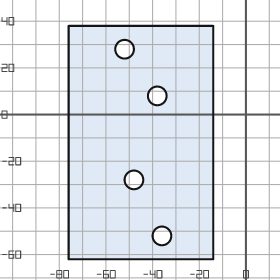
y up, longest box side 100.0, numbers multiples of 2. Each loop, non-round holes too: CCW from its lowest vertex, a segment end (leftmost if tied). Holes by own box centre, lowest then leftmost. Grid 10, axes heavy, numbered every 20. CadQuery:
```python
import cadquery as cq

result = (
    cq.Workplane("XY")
    .moveTo(-76.0, -62.0)
    .lineTo(-14.0, -62.0)
    .lineTo(-14.0, 38.0)
    .lineTo(-76.0, 38.0)
    .close()
    .moveTo(-36.0, -52.0)
    .circle(4.0)
    .moveTo(-48.0, -28.0)
    .circle(4.0)
    .moveTo(-38.0, 8.0)
    .circle(4.0)
    .moveTo(-52.0, 28.0)
    .circle(4.0)
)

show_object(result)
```